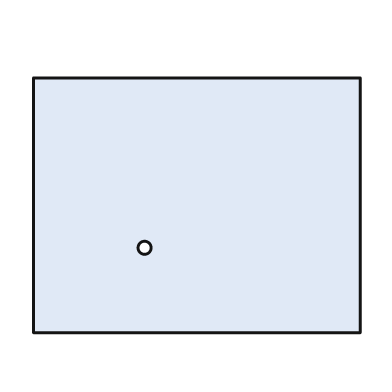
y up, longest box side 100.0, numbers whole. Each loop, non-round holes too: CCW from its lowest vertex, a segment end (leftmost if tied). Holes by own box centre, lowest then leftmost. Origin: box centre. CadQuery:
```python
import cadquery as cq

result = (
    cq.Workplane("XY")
    .moveTo(-50.0, -39.0)
    .lineTo(50.0, -39.0)
    .lineTo(50.0, 39.0)
    .lineTo(-50.0, 39.0)
    .close()
    .moveTo(-16.0, -13.0)
    .circle(2.0)
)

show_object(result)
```